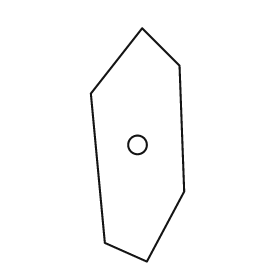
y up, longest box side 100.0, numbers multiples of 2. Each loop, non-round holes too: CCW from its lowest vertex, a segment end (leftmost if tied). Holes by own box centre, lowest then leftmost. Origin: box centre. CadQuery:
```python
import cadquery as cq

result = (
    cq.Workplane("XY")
    .moveTo(4.0, -50.0)
    .lineTo(20.0, -20.0)
    .lineTo(18.0, 34.0)
    .lineTo(2.0, 50.0)
    .lineTo(-20.0, 22.0)
    .lineTo(-14.0, -42.0)
    .close()
    .moveTo(0.0, 0.0)
    .circle(4.0)
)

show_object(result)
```